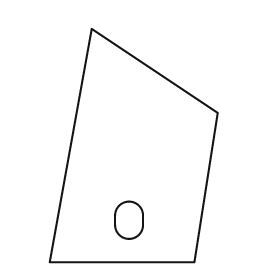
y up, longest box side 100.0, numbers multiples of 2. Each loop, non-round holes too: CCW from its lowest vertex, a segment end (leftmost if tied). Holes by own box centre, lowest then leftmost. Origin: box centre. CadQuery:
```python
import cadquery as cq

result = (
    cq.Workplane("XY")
    .moveTo(-36.0, -50.0)
    .lineTo(26.0, -50.0)
    .lineTo(36.0, 14.0)
    .lineTo(-18.0, 50.0)
    .close()
    .moveTo(-8.0, -34.0)
    .threePointArc((-2.0, -40.0), (4.0, -34.0))
    .lineTo(4.0, -30.0)
    .threePointArc((-2.0, -24.0), (-8.0, -30.0))
    .close()
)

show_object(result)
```